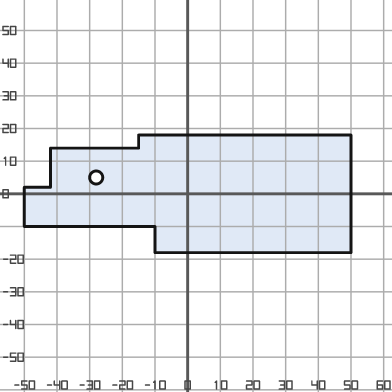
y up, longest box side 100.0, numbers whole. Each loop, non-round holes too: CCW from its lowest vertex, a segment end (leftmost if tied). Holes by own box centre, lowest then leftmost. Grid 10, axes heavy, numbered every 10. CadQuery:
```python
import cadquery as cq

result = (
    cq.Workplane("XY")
    .moveTo(-10.0, -18.0)
    .lineTo(50.0, -18.0)
    .lineTo(50.0, 18.0)
    .lineTo(-15.0, 18.0)
    .lineTo(-15.0, 14.0)
    .lineTo(-42.0, 14.0)
    .lineTo(-42.0, 2.0)
    .lineTo(-50.0, 2.0)
    .lineTo(-50.0, -10.0)
    .lineTo(-10.0, -10.0)
    .close()
    .moveTo(-28.0, 5.0)
    .circle(2.0)
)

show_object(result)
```